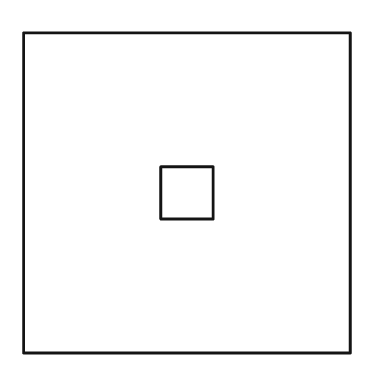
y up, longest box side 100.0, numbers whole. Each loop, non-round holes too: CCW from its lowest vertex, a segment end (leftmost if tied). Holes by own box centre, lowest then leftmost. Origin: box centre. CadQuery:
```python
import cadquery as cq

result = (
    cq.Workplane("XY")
    .moveTo(-50.0, -49.0)
    .lineTo(50.0, -49.0)
    .lineTo(50.0, 49.0)
    .lineTo(-50.0, 49.0)
    .close()
    .moveTo(-8.0, -8.0)
    .lineTo(8.0, -8.0)
    .lineTo(8.0, 8.0)
    .lineTo(-8.0, 8.0)
    .close()
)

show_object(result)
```